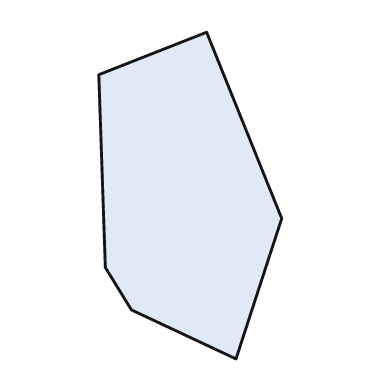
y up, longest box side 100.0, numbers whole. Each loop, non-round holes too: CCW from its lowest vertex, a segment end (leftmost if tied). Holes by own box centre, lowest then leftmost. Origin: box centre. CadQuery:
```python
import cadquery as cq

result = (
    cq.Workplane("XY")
    .moveTo(14.0, -50.0)
    .lineTo(28.0, -7.0)
    .lineTo(5.0, 50.0)
    .lineTo(-28.0, 37.0)
    .lineTo(-26.0, -22.0)
    .lineTo(-18.0, -35.0)
    .close()
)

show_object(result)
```